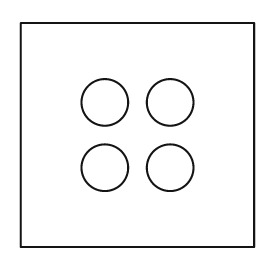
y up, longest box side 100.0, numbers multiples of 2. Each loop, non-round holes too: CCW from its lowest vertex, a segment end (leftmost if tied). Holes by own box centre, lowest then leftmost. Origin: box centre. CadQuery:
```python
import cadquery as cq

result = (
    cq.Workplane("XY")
    .moveTo(-50.0, -48.0)
    .lineTo(50.0, -48.0)
    .lineTo(50.0, 48.0)
    .lineTo(-50.0, 48.0)
    .close()
    .moveTo(-14.0, -14.0)
    .circle(10.0)
    .moveTo(14.0, -14.0)
    .circle(10.0)
    .moveTo(-14.0, 14.0)
    .circle(10.0)
    .moveTo(14.0, 14.0)
    .circle(10.0)
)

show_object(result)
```